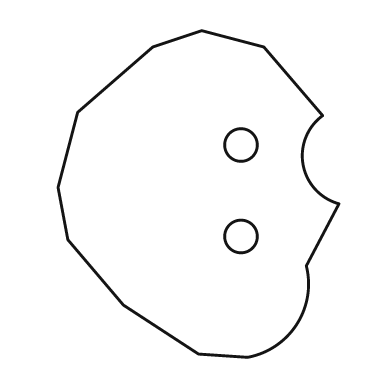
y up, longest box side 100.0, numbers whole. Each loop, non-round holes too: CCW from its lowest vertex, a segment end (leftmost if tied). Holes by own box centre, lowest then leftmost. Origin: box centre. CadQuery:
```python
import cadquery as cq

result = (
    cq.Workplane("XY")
    .moveTo(15.0, -50.0)
    .threePointArc((30.0, -40.0), (33.0, -22.0))
    .lineTo(43.0, -3.0)
    .threePointArc((32.0, 9.0), (38.0, 24.0))
    .lineTo(20.0, 45.0)
    .lineTo(1.0, 50.0)
    .lineTo(-14.0, 45.0)
    .lineTo(-37.0, 25.0)
    .lineTo(-43.0, 2.0)
    .lineTo(-40.0, -14.0)
    .lineTo(-23.0, -34.0)
    .lineTo(0.0, -49.0)
    .close()
    .moveTo(13.0, -13.0)
    .circle(5.0)
    .moveTo(13.0, 15.0)
    .circle(5.0)
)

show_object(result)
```